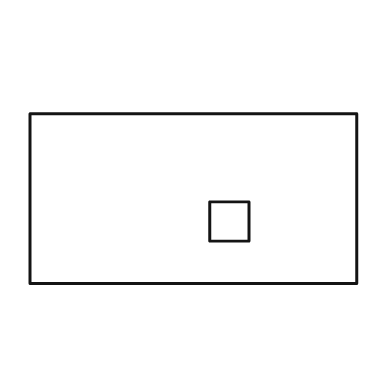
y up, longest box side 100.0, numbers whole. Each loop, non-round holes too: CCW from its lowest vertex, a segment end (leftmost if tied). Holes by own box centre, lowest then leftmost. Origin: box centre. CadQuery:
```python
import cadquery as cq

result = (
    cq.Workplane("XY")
    .moveTo(-50.0, -26.0)
    .lineTo(50.0, -26.0)
    .lineTo(50.0, 26.0)
    .lineTo(-50.0, 26.0)
    .close()
    .moveTo(5.0, -13.0)
    .lineTo(17.0, -13.0)
    .lineTo(17.0, -1.0)
    .lineTo(5.0, -1.0)
    .close()
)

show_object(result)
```